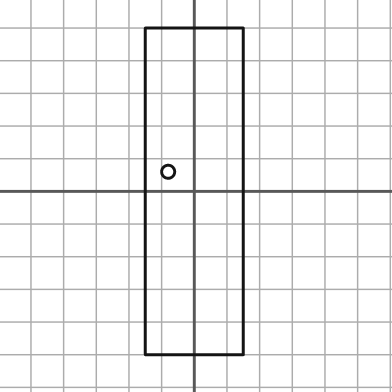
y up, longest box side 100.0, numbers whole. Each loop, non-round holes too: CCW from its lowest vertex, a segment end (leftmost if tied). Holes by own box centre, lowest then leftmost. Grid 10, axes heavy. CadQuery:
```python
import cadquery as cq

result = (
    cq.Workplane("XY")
    .moveTo(-15.0, -50.0)
    .lineTo(15.0, -50.0)
    .lineTo(15.0, 50.0)
    .lineTo(-15.0, 50.0)
    .close()
    .moveTo(-8.0, 6.0)
    .circle(2.0)
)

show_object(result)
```